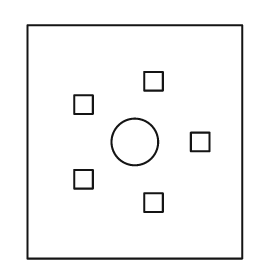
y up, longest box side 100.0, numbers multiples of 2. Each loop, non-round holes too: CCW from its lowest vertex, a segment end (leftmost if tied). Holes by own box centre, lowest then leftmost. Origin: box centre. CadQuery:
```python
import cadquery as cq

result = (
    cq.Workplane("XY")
    .moveTo(-46.0, -50.0)
    .lineTo(46.0, -50.0)
    .lineTo(46.0, 50.0)
    .lineTo(-46.0, 50.0)
    .close()
    .moveTo(4.0, -30.0)
    .lineTo(12.0, -30.0)
    .lineTo(12.0, -22.0)
    .lineTo(4.0, -22.0)
    .close()
    .moveTo(-26.0, -20.0)
    .lineTo(-18.0, -20.0)
    .lineTo(-18.0, -12.0)
    .lineTo(-26.0, -12.0)
    .close()
    .moveTo(0.0, 0.0)
    .circle(10.0)
    .moveTo(24.0, -4.0)
    .lineTo(32.0, -4.0)
    .lineTo(32.0, 4.0)
    .lineTo(24.0, 4.0)
    .close()
    .moveTo(-26.0, 12.0)
    .lineTo(-18.0, 12.0)
    .lineTo(-18.0, 20.0)
    .lineTo(-26.0, 20.0)
    .close()
    .moveTo(4.0, 22.0)
    .lineTo(12.0, 22.0)
    .lineTo(12.0, 30.0)
    .lineTo(4.0, 30.0)
    .close()
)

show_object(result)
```